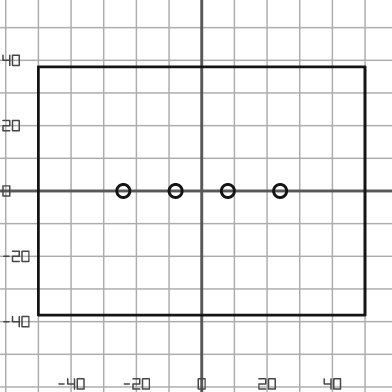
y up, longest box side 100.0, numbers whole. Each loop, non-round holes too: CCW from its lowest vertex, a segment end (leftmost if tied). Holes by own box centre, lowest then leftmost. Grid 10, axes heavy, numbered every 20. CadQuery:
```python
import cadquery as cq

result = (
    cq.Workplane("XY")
    .moveTo(-50.0, -38.0)
    .lineTo(50.0, -38.0)
    .lineTo(50.0, 38.0)
    .lineTo(-50.0, 38.0)
    .close()
    .moveTo(-24.0, 0.0)
    .circle(2.0)
    .moveTo(-8.0, 0.0)
    .circle(2.0)
    .moveTo(8.0, 0.0)
    .circle(2.0)
    .moveTo(24.0, 0.0)
    .circle(2.0)
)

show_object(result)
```